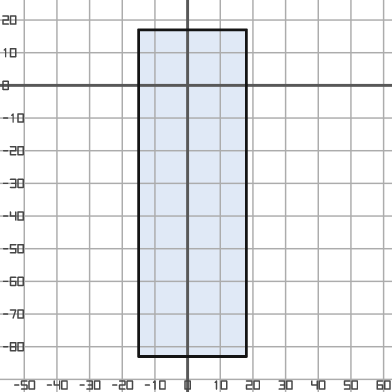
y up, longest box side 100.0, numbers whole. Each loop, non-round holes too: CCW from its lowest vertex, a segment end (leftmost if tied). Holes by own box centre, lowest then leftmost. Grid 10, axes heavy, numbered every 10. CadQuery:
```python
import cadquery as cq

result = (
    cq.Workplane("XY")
    .moveTo(-15.0, -83.0)
    .lineTo(18.0, -83.0)
    .lineTo(18.0, 17.0)
    .lineTo(-15.0, 17.0)
    .close()
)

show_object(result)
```